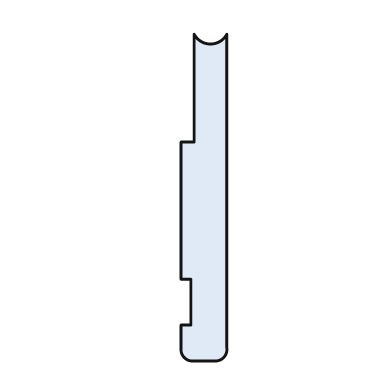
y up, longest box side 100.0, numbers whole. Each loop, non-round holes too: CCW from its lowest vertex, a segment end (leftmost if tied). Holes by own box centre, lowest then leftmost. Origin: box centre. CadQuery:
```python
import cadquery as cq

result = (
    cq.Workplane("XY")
    .moveTo(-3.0, -50.0)
    .lineTo(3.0, -50.0)
    .threePointArc((6.0, -49.0), (7.0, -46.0))
    .lineTo(7.0, 50.0)
    .threePointArc((2.0, 47.0), (-3.0, 50.0))
    .lineTo(-3.0, 17.0)
    .lineTo(-7.0, 17.0)
    .lineTo(-7.0, -25.0)
    .lineTo(-4.0, -25.0)
    .lineTo(-4.0, -39.0)
    .lineTo(-7.0, -39.0)
    .lineTo(-7.0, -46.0)
    .threePointArc((-6.0, -49.0), (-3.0, -50.0))
    .close()
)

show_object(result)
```